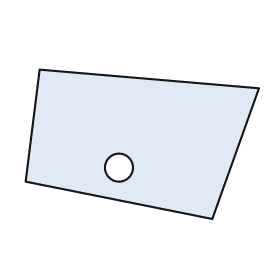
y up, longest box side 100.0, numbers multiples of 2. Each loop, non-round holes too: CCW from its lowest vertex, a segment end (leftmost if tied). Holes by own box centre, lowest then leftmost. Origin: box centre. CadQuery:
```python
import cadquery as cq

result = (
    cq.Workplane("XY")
    .moveTo(30.0, -32.0)
    .lineTo(50.0, 24.0)
    .lineTo(-44.0, 32.0)
    .lineTo(-50.0, -16.0)
    .close()
    .moveTo(-10.0, -10.0)
    .circle(6.0)
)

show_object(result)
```